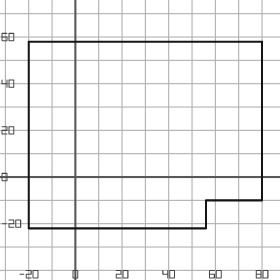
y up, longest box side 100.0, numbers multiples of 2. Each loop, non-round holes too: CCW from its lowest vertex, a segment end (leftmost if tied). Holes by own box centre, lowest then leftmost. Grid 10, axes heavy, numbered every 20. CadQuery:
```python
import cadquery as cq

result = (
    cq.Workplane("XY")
    .moveTo(-20.0, -22.0)
    .lineTo(56.0, -22.0)
    .lineTo(56.0, -10.0)
    .lineTo(80.0, -10.0)
    .lineTo(80.0, 58.0)
    .lineTo(-20.0, 58.0)
    .close()
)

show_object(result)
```